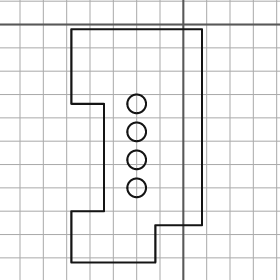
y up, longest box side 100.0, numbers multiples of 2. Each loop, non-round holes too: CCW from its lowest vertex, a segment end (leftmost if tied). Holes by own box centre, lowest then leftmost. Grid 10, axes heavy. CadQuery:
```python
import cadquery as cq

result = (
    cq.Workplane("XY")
    .moveTo(-48.0, -102.0)
    .lineTo(-12.0, -102.0)
    .lineTo(-12.0, -86.0)
    .lineTo(8.0, -86.0)
    .lineTo(8.0, -2.0)
    .lineTo(-48.0, -2.0)
    .lineTo(-48.0, -34.0)
    .lineTo(-34.0, -34.0)
    .lineTo(-34.0, -80.0)
    .lineTo(-48.0, -80.0)
    .close()
    .moveTo(-20.0, -70.0)
    .circle(4.0)
    .moveTo(-20.0, -58.0)
    .circle(4.0)
    .moveTo(-20.0, -46.0)
    .circle(4.0)
    .moveTo(-20.0, -34.0)
    .circle(4.0)
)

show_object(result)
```